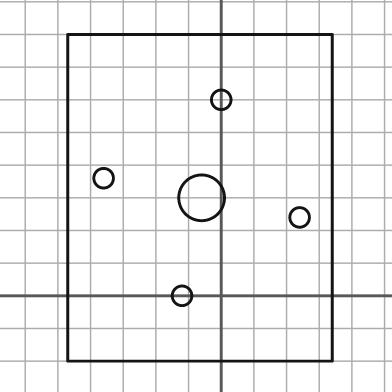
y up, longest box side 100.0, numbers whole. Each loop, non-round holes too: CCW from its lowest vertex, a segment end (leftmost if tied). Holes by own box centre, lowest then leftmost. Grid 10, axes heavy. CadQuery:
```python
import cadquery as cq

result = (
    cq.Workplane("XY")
    .moveTo(-47.0, -20.0)
    .lineTo(34.0, -20.0)
    .lineTo(34.0, 80.0)
    .lineTo(-47.0, 80.0)
    .close()
    .moveTo(-12.0, 0.0)
    .circle(3.0)
    .moveTo(24.0, 24.0)
    .circle(3.0)
    .moveTo(-6.0, 30.0)
    .circle(7.0)
    .moveTo(-36.0, 36.0)
    .circle(3.0)
    .moveTo(0.0, 60.0)
    .circle(3.0)
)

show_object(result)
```